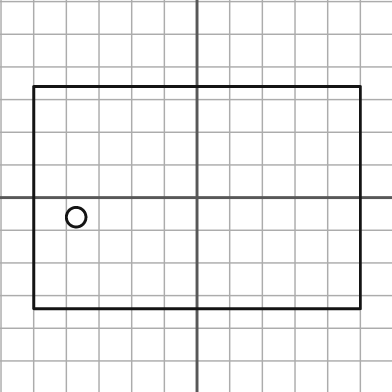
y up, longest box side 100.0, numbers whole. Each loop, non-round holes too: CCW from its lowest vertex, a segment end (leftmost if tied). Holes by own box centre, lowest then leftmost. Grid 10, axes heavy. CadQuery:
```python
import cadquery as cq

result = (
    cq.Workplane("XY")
    .moveTo(-50.0, -34.0)
    .lineTo(50.0, -34.0)
    .lineTo(50.0, 34.0)
    .lineTo(-50.0, 34.0)
    .close()
    .moveTo(-37.0, -6.0)
    .circle(3.0)
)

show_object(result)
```